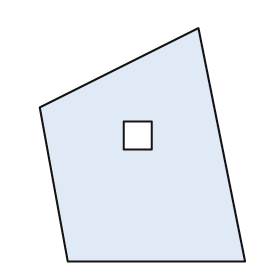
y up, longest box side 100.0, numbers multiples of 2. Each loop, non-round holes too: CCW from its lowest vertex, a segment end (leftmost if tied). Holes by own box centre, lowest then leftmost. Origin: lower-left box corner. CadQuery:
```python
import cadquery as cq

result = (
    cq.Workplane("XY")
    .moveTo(12.0, 0.0)
    .lineTo(88.0, 0.0)
    .lineTo(68.0, 100.0)
    .lineTo(0.0, 66.0)
    .close()
    .moveTo(36.0, 48.0)
    .lineTo(48.0, 48.0)
    .lineTo(48.0, 60.0)
    .lineTo(36.0, 60.0)
    .close()
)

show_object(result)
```